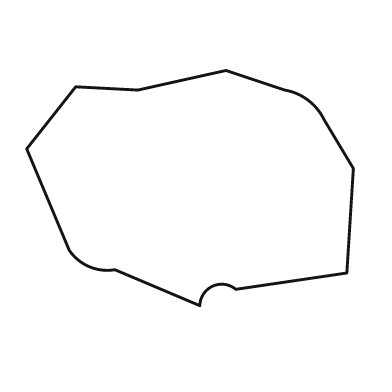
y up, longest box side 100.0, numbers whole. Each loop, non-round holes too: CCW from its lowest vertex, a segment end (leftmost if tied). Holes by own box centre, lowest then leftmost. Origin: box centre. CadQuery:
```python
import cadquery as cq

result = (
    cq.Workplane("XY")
    .moveTo(3.0, -36.0)
    .threePointArc((7.0, -30.0), (14.0, -31.0))
    .lineTo(48.0, -26.0)
    .lineTo(50.0, 6.0)
    .lineTo(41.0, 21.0)
    .threePointArc((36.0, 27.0), (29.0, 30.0))
    .lineTo(11.0, 36.0)
    .lineTo(-16.0, 30.0)
    .lineTo(-35.0, 31.0)
    .lineTo(-50.0, 12.0)
    .lineTo(-37.0, -19.0)
    .threePointArc((-31.0, -24.0), (-23.0, -25.0))
    .close()
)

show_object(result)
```